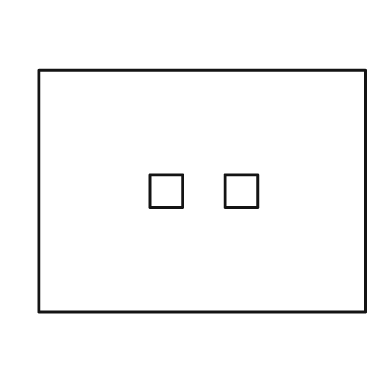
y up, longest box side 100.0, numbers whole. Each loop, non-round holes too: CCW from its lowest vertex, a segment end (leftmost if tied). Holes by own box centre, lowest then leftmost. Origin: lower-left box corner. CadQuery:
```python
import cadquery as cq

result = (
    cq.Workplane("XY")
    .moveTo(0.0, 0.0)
    .lineTo(100.0, 0.0)
    .lineTo(100.0, 74.0)
    .lineTo(0.0, 74.0)
    .close()
    .moveTo(34.0, 32.0)
    .lineTo(44.0, 32.0)
    .lineTo(44.0, 42.0)
    .lineTo(34.0, 42.0)
    .close()
    .moveTo(57.0, 32.0)
    .lineTo(67.0, 32.0)
    .lineTo(67.0, 42.0)
    .lineTo(57.0, 42.0)
    .close()
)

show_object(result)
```